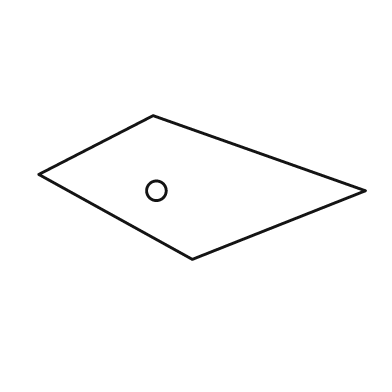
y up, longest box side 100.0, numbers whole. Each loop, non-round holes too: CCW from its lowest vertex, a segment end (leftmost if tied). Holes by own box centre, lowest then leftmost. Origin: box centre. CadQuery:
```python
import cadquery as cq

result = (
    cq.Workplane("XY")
    .moveTo(-3.0, -22.0)
    .lineTo(50.0, -1.0)
    .lineTo(-15.0, 22.0)
    .lineTo(-50.0, 4.0)
    .close()
    .moveTo(-14.0, -1.0)
    .circle(3.0)
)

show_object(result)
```